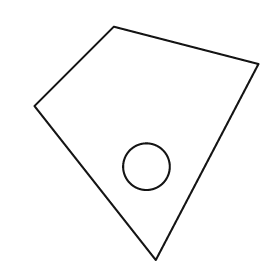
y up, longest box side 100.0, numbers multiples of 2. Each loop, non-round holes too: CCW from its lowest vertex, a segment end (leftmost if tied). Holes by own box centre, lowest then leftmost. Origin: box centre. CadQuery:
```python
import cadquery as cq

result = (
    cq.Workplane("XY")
    .moveTo(4.0, -50.0)
    .lineTo(48.0, 34.0)
    .lineTo(-14.0, 50.0)
    .lineTo(-48.0, 16.0)
    .close()
    .moveTo(0.0, -10.0)
    .circle(10.0)
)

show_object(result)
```